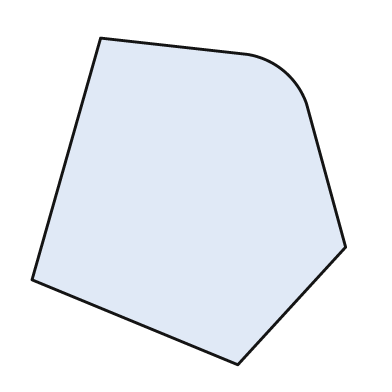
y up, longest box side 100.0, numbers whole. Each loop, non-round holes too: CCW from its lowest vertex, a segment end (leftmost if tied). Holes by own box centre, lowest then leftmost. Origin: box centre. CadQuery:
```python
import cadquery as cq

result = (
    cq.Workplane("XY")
    .moveTo(15.0, -50.0)
    .lineTo(48.0, -14.0)
    .lineTo(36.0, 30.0)
    .threePointArc((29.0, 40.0), (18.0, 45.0))
    .lineTo(-27.0, 50.0)
    .lineTo(-48.0, -24.0)
    .close()
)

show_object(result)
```